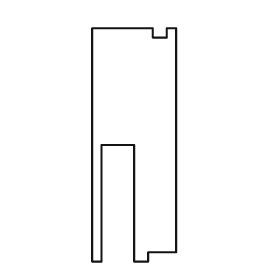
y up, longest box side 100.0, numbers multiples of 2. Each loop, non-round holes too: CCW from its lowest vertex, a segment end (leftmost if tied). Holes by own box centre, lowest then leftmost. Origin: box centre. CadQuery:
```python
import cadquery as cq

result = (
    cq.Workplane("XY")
    .moveTo(-18.0, -50.0)
    .lineTo(-14.0, -50.0)
    .lineTo(-14.0, 0.0)
    .lineTo(0.0, 0.0)
    .lineTo(0.0, -50.0)
    .lineTo(6.0, -50.0)
    .lineTo(6.0, -46.0)
    .lineTo(18.0, -46.0)
    .lineTo(18.0, 50.0)
    .lineTo(14.0, 50.0)
    .lineTo(14.0, 46.0)
    .lineTo(8.0, 46.0)
    .lineTo(8.0, 50.0)
    .lineTo(-18.0, 50.0)
    .close()
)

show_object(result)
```